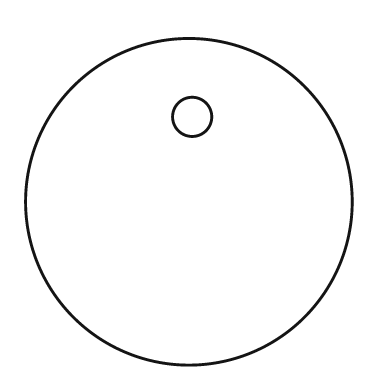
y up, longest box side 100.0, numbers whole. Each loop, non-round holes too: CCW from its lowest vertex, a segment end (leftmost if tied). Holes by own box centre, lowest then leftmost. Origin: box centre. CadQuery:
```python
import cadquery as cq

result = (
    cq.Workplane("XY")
    .moveTo(0.0, 0.0)
    .circle(50.0)
    .moveTo(1.0, 26.0)
    .circle(6.0)
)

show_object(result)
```